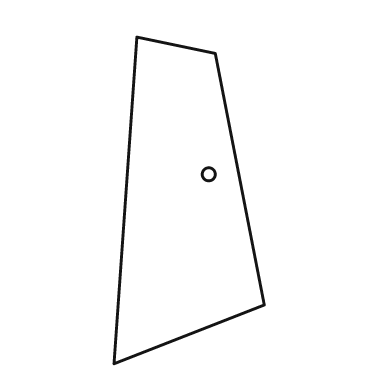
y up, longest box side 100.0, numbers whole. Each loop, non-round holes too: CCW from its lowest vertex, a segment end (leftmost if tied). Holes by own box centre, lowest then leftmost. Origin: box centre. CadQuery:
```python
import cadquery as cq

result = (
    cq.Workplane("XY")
    .moveTo(-23.0, -50.0)
    .lineTo(23.0, -32.0)
    .lineTo(8.0, 45.0)
    .lineTo(-16.0, 50.0)
    .close()
    .moveTo(6.0, 8.0)
    .circle(2.0)
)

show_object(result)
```